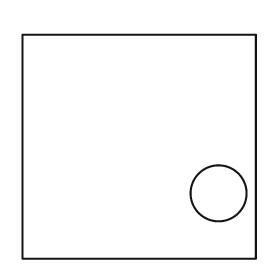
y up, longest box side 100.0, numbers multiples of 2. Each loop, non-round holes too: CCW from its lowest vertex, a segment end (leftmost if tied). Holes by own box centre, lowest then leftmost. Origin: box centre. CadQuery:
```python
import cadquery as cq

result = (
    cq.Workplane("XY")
    .moveTo(-50.0, -48.0)
    .lineTo(50.0, -48.0)
    .lineTo(50.0, 48.0)
    .lineTo(-50.0, 48.0)
    .close()
    .moveTo(34.0, -20.0)
    .circle(12.0)
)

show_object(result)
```